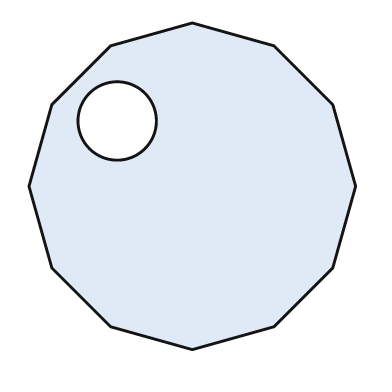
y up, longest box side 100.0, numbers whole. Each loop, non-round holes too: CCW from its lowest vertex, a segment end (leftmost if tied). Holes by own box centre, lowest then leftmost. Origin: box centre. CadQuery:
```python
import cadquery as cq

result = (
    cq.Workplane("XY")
    .moveTo(0.0, -50.0)
    .lineTo(25.0, -43.0)
    .lineTo(43.0, -25.0)
    .lineTo(50.0, 0.0)
    .lineTo(43.0, 25.0)
    .lineTo(25.0, 43.0)
    .lineTo(0.0, 50.0)
    .lineTo(-25.0, 43.0)
    .lineTo(-43.0, 25.0)
    .lineTo(-50.0, 0.0)
    .lineTo(-43.0, -25.0)
    .lineTo(-25.0, -43.0)
    .close()
    .moveTo(-23.0, 20.0)
    .circle(12.0)
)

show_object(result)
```